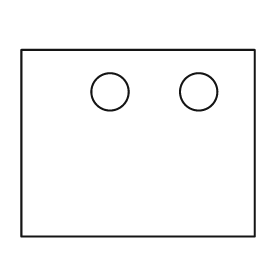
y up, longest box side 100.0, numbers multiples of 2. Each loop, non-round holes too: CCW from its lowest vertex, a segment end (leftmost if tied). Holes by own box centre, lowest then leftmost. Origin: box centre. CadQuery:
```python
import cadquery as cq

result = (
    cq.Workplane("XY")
    .moveTo(-50.0, -40.0)
    .lineTo(50.0, -40.0)
    .lineTo(50.0, 40.0)
    .lineTo(-50.0, 40.0)
    .close()
    .moveTo(-12.0, 22.0)
    .circle(8.0)
    .moveTo(26.0, 22.0)
    .circle(8.0)
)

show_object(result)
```